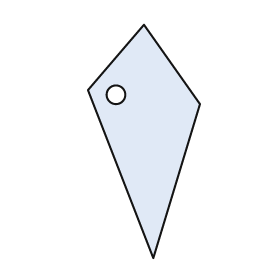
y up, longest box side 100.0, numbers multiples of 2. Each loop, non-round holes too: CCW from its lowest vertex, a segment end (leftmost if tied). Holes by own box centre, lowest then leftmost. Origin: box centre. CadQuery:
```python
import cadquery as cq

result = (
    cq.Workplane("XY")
    .moveTo(4.0, -50.0)
    .lineTo(24.0, 16.0)
    .lineTo(0.0, 50.0)
    .lineTo(-24.0, 22.0)
    .close()
    .moveTo(-12.0, 20.0)
    .circle(4.0)
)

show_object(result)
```